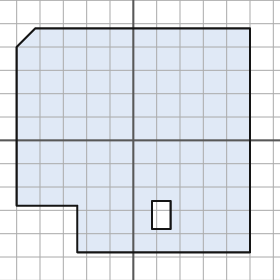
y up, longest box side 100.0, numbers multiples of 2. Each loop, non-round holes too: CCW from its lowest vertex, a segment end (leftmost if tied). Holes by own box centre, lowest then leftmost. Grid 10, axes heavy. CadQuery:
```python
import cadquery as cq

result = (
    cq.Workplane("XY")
    .moveTo(-24.0, -48.0)
    .lineTo(50.0, -48.0)
    .lineTo(50.0, 48.0)
    .lineTo(-42.0, 48.0)
    .lineTo(-50.0, 40.0)
    .lineTo(-50.0, -28.0)
    .lineTo(-24.0, -28.0)
    .close()
    .moveTo(8.0, -38.0)
    .lineTo(16.0, -38.0)
    .lineTo(16.0, -26.0)
    .lineTo(8.0, -26.0)
    .close()
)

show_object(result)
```